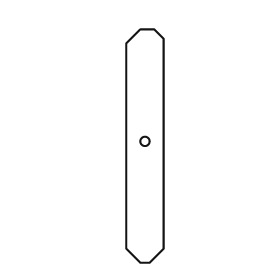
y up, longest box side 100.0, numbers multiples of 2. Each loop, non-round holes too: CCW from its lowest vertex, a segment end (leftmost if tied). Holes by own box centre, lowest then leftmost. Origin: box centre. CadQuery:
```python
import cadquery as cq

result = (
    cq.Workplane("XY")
    .moveTo(-2.0, -50.0)
    .lineTo(2.0, -50.0)
    .lineTo(8.0, -44.0)
    .lineTo(8.0, 46.0)
    .lineTo(4.0, 50.0)
    .lineTo(-2.0, 50.0)
    .lineTo(-8.0, 44.0)
    .lineTo(-8.0, -44.0)
    .close()
    .moveTo(0.0, 2.0)
    .circle(2.0)
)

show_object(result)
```